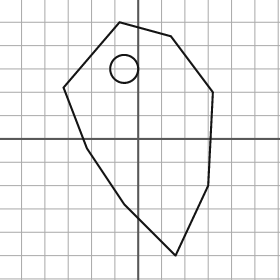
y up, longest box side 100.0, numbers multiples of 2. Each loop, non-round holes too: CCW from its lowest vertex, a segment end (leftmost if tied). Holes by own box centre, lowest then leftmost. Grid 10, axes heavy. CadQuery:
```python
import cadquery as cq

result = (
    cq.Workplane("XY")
    .moveTo(16.0, -50.0)
    .lineTo(30.0, -20.0)
    .lineTo(32.0, 20.0)
    .lineTo(14.0, 44.0)
    .lineTo(-8.0, 50.0)
    .lineTo(-32.0, 22.0)
    .lineTo(-22.0, -4.0)
    .lineTo(-6.0, -28.0)
    .close()
    .moveTo(-6.0, 30.0)
    .circle(6.0)
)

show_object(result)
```